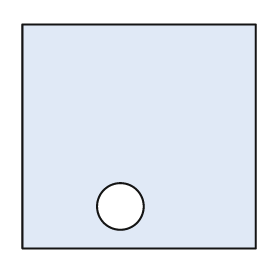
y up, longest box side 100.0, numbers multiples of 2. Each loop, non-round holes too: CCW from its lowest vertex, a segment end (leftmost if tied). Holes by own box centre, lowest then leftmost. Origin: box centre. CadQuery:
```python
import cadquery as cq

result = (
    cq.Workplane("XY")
    .moveTo(-50.0, -48.0)
    .lineTo(50.0, -48.0)
    .lineTo(50.0, 48.0)
    .lineTo(-50.0, 48.0)
    .close()
    .moveTo(-8.0, -30.0)
    .circle(10.0)
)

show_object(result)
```